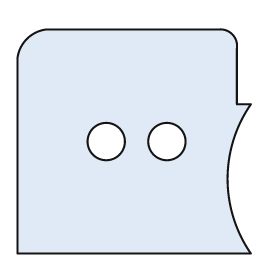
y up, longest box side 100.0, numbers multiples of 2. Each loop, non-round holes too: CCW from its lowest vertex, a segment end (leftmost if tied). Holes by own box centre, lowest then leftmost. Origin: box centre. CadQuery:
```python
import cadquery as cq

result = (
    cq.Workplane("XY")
    .moveTo(-50.0, -48.0)
    .lineTo(50.0, -48.0)
    .threePointArc((40.0, -16.0), (50.0, 16.0))
    .lineTo(44.0, 16.0)
    .lineTo(44.0, 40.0)
    .threePointArc((42.0, 46.0), (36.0, 48.0))
    .lineTo(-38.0, 48.0)
    .threePointArc((-46.0, 44.0), (-50.0, 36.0))
    .close()
    .moveTo(-12.0, 0.0)
    .circle(8.0)
    .moveTo(14.0, 0.0)
    .circle(8.0)
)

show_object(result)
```